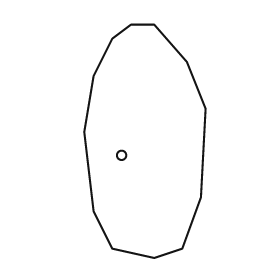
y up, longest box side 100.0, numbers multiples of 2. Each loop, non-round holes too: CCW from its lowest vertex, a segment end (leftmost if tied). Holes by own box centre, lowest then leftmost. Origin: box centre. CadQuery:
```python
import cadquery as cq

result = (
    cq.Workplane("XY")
    .moveTo(4.0, -50.0)
    .lineTo(16.0, -46.0)
    .lineTo(24.0, -24.0)
    .lineTo(26.0, 14.0)
    .lineTo(18.0, 34.0)
    .lineTo(4.0, 50.0)
    .lineTo(-6.0, 50.0)
    .lineTo(-14.0, 44.0)
    .lineTo(-22.0, 28.0)
    .lineTo(-26.0, 4.0)
    .lineTo(-22.0, -30.0)
    .lineTo(-14.0, -46.0)
    .close()
    .moveTo(-10.0, -6.0)
    .circle(2.0)
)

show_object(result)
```